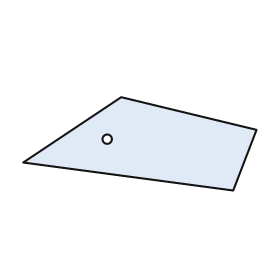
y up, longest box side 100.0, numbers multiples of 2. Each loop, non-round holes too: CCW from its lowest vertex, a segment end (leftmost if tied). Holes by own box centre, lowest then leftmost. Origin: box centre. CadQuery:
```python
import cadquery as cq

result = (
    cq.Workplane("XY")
    .moveTo(40.0, -20.0)
    .lineTo(50.0, 6.0)
    .lineTo(-8.0, 20.0)
    .lineTo(-50.0, -8.0)
    .close()
    .moveTo(-14.0, 2.0)
    .circle(2.0)
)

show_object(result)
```